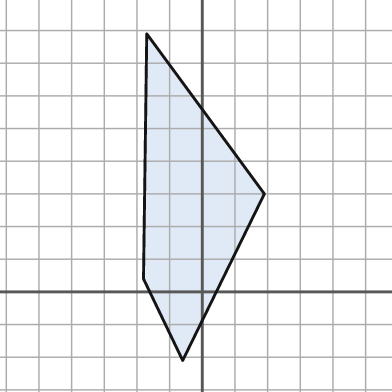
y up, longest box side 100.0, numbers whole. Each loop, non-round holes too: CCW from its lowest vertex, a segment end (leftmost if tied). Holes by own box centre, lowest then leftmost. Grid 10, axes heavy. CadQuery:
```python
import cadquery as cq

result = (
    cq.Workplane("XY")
    .moveTo(-6.0, -21.0)
    .lineTo(19.0, 30.0)
    .lineTo(-17.0, 79.0)
    .lineTo(-18.0, 4.0)
    .close()
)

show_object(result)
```